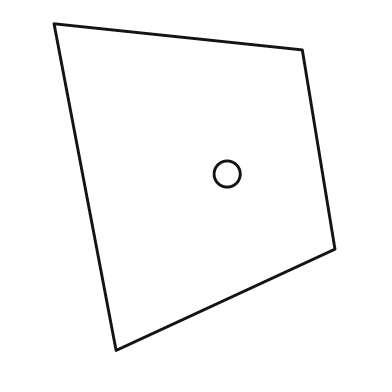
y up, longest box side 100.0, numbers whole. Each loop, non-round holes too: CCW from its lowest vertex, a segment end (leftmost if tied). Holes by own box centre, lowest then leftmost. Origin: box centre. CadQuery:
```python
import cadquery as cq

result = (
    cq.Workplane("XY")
    .moveTo(-24.0, -50.0)
    .lineTo(43.0, -19.0)
    .lineTo(33.0, 42.0)
    .lineTo(-43.0, 50.0)
    .close()
    .moveTo(10.0, 4.0)
    .circle(4.0)
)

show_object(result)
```